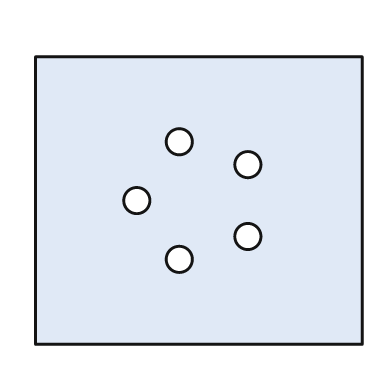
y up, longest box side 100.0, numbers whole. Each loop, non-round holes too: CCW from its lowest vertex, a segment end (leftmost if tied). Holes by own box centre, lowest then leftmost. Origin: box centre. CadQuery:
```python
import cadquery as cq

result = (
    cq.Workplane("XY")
    .moveTo(-50.0, -44.0)
    .lineTo(50.0, -44.0)
    .lineTo(50.0, 44.0)
    .lineTo(-50.0, 44.0)
    .close()
    .moveTo(-6.0, -18.0)
    .circle(4.0)
    .moveTo(15.0, -11.0)
    .circle(4.0)
    .moveTo(-19.0, 0.0)
    .circle(4.0)
    .moveTo(15.0, 11.0)
    .circle(4.0)
    .moveTo(-6.0, 18.0)
    .circle(4.0)
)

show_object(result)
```